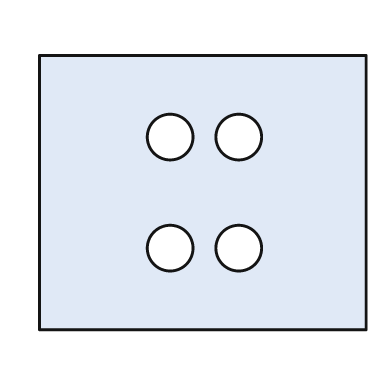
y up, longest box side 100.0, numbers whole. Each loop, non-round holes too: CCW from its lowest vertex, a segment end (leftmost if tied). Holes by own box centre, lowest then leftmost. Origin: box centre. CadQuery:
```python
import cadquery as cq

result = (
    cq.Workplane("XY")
    .moveTo(-50.0, -42.0)
    .lineTo(50.0, -42.0)
    .lineTo(50.0, 42.0)
    .lineTo(-50.0, 42.0)
    .close()
    .moveTo(-10.0, -17.0)
    .circle(7.0)
    .moveTo(11.0, -17.0)
    .circle(7.0)
    .moveTo(-10.0, 17.0)
    .circle(7.0)
    .moveTo(11.0, 17.0)
    .circle(7.0)
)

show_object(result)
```